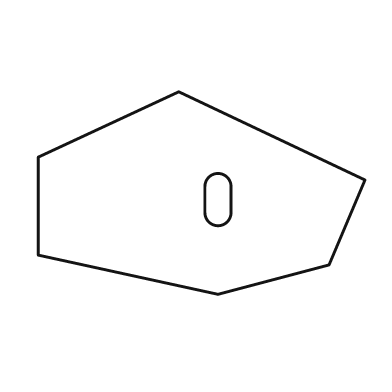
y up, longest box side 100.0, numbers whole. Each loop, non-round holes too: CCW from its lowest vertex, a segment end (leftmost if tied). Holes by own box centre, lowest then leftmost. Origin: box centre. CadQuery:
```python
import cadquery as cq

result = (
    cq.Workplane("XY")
    .moveTo(5.0, -31.0)
    .lineTo(39.0, -22.0)
    .lineTo(50.0, 4.0)
    .lineTo(-7.0, 31.0)
    .lineTo(-50.0, 11.0)
    .lineTo(-50.0, -19.0)
    .close()
    .moveTo(1.0, -6.0)
    .threePointArc((5.0, -10.0), (9.0, -6.0))
    .lineTo(9.0, 2.0)
    .threePointArc((5.0, 6.0), (1.0, 2.0))
    .close()
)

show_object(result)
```